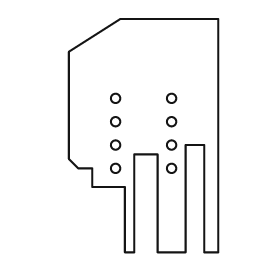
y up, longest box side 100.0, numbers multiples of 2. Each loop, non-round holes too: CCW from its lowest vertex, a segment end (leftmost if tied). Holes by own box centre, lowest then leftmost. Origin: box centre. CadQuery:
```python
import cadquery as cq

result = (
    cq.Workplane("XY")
    .moveTo(-8.0, -50.0)
    .lineTo(-4.0, -50.0)
    .lineTo(-4.0, -8.0)
    .lineTo(6.0, -8.0)
    .lineTo(6.0, -50.0)
    .lineTo(18.0, -50.0)
    .lineTo(18.0, -4.0)
    .lineTo(26.0, -4.0)
    .lineTo(26.0, -50.0)
    .lineTo(32.0, -50.0)
    .lineTo(32.0, 50.0)
    .lineTo(-10.0, 50.0)
    .lineTo(-32.0, 36.0)
    .lineTo(-32.0, -10.0)
    .lineTo(-28.0, -14.0)
    .lineTo(-22.0, -14.0)
    .lineTo(-22.0, -22.0)
    .lineTo(-8.0, -22.0)
    .close()
    .moveTo(-12.0, -14.0)
    .circle(2.0)
    .moveTo(12.0, -14.0)
    .circle(2.0)
    .moveTo(-12.0, -4.0)
    .circle(2.0)
    .moveTo(12.0, -4.0)
    .circle(2.0)
    .moveTo(-12.0, 6.0)
    .circle(2.0)
    .moveTo(12.0, 6.0)
    .circle(2.0)
    .moveTo(-12.0, 16.0)
    .circle(2.0)
    .moveTo(12.0, 16.0)
    .circle(2.0)
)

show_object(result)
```